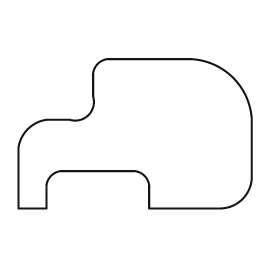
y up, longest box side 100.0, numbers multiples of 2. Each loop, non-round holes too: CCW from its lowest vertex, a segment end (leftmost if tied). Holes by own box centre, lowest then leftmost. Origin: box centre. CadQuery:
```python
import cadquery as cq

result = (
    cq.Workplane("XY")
    .moveTo(-50.0, -32.0)
    .lineTo(-38.0, -32.0)
    .lineTo(-38.0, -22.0)
    .threePointArc((-36.0, -18.0), (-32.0, -16.0))
    .lineTo(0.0, -16.0)
    .threePointArc((4.0, -18.0), (6.0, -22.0))
    .lineTo(6.0, -32.0)
    .lineTo(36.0, -32.0)
    .threePointArc((46.0, -28.0), (50.0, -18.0))
    .lineTo(50.0, 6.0)
    .threePointArc((42.0, 24.0), (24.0, 32.0))
    .lineTo(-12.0, 32.0)
    .threePointArc((-16.0, 30.0), (-18.0, 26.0))
    .lineTo(-18.0, 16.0)
    .threePointArc((-20.0, 8.0), (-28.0, 6.0))
    .lineTo(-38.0, 6.0)
    .threePointArc((-46.0, 2.0), (-50.0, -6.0))
    .close()
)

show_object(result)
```